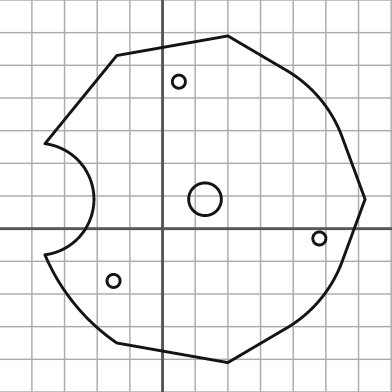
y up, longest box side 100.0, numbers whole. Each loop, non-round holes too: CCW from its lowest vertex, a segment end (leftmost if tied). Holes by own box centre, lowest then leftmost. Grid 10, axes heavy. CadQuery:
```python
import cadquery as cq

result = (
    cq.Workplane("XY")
    .moveTo(20.0, -41.0)
    .lineTo(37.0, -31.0)
    .threePointArc((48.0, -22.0), (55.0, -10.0))
    .lineTo(62.0, 9.0)
    .lineTo(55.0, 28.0)
    .threePointArc((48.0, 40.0), (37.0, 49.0))
    .lineTo(20.0, 59.0)
    .lineTo(-14.0, 53.0)
    .lineTo(-36.0, 26.0)
    .threePointArc((-21.0, 9.0), (-36.0, -8.0))
    .threePointArc((-27.0, -23.0), (-14.0, -35.0))
    .close()
    .moveTo(-15.0, -16.0)
    .circle(2.0)
    .moveTo(48.0, -3.0)
    .circle(2.0)
    .moveTo(13.0, 9.0)
    .circle(5.0)
    .moveTo(5.0, 45.0)
    .circle(2.0)
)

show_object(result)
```